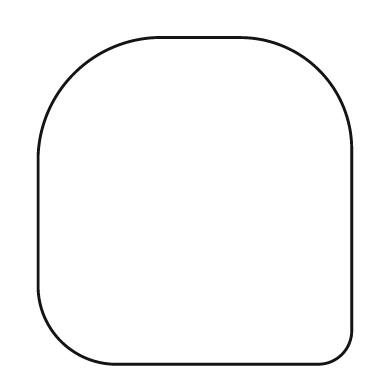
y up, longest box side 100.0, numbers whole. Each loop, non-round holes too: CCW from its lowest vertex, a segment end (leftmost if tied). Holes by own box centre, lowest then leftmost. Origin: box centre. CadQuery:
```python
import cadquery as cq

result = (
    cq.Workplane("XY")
    .moveTo(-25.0, -50.0)
    .lineTo(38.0, -50.0)
    .threePointArc((45.0, -47.0), (48.0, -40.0))
    .lineTo(48.0, 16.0)
    .threePointArc((38.0, 40.0), (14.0, 50.0))
    .lineTo(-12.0, 50.0)
    .threePointArc((-37.0, 39.0), (-48.0, 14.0))
    .lineTo(-48.0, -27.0)
    .threePointArc((-41.0, -43.0), (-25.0, -50.0))
    .close()
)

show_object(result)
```